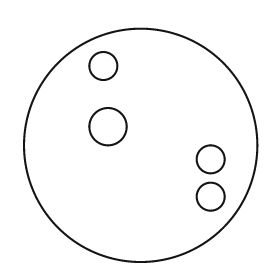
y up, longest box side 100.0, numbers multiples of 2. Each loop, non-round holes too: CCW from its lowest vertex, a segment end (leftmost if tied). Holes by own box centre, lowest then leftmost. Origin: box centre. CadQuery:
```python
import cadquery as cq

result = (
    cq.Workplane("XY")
    .moveTo(0.0, 0.0)
    .circle(50.0)
    .moveTo(30.0, -22.0)
    .circle(6.0)
    .moveTo(30.0, -6.0)
    .circle(6.0)
    .moveTo(-14.0, 8.0)
    .circle(8.0)
    .moveTo(-16.0, 34.0)
    .circle(6.0)
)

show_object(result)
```